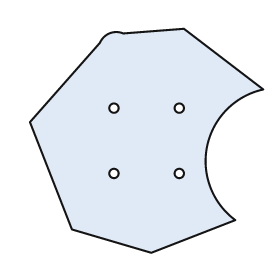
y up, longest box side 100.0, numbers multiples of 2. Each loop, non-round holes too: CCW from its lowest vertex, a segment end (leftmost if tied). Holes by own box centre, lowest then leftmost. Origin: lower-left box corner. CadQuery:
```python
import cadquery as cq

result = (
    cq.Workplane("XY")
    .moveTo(52.0, 0.0)
    .lineTo(88.0, 14.0)
    .threePointArc((76.0, 46.0), (100.0, 70.0))
    .lineTo(66.0, 96.0)
    .lineTo(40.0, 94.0)
    .threePointArc((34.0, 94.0), (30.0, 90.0))
    .lineTo(0.0, 56.0)
    .lineTo(18.0, 10.0)
    .close()
    .moveTo(36.0, 34.0)
    .circle(2.0)
    .moveTo(64.0, 34.0)
    .circle(2.0)
    .moveTo(36.0, 62.0)
    .circle(2.0)
    .moveTo(64.0, 62.0)
    .circle(2.0)
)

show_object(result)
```